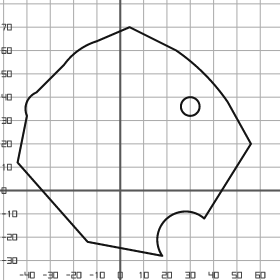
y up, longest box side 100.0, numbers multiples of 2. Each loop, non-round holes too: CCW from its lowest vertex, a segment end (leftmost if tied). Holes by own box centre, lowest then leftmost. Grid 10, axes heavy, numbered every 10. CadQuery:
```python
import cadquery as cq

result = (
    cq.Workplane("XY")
    .moveTo(18.0, -28.0)
    .threePointArc((20.0, -12.0), (36.0, -12.0))
    .lineTo(56.0, 20.0)
    .lineTo(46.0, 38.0)
    .threePointArc((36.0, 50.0), (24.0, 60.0))
    .lineTo(4.0, 70.0)
    .lineTo(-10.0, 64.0)
    .threePointArc((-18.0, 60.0), (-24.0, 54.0))
    .lineTo(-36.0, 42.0)
    .threePointArc((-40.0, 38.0), (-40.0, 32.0))
    .lineTo(-44.0, 12.0)
    .lineTo(-14.0, -22.0)
    .close()
    .moveTo(30.0, 36.0)
    .circle(4.0)
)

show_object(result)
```